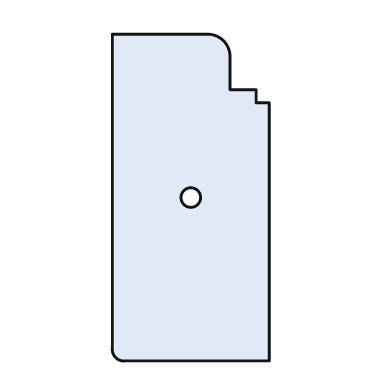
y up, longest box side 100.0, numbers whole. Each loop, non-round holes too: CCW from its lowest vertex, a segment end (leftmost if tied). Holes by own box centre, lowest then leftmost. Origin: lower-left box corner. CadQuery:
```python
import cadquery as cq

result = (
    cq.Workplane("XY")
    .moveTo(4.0, 0.0)
    .lineTo(48.0, 0.0)
    .lineTo(48.0, 79.0)
    .lineTo(44.0, 79.0)
    .lineTo(44.0, 83.0)
    .lineTo(36.0, 83.0)
    .lineTo(36.0, 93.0)
    .threePointArc((34.0, 98.0), (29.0, 100.0))
    .lineTo(0.0, 100.0)
    .lineTo(0.0, 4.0)
    .threePointArc((1.0, 1.0), (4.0, 0.0))
    .close()
    .moveTo(24.0, 50.0)
    .circle(3.0)
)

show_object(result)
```